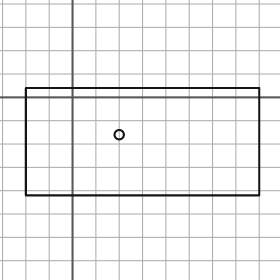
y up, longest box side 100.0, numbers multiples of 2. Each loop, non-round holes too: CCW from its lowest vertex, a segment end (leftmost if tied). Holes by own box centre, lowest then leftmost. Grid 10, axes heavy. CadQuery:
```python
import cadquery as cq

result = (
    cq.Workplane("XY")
    .moveTo(-20.0, -42.0)
    .lineTo(80.0, -42.0)
    .lineTo(80.0, 4.0)
    .lineTo(-20.0, 4.0)
    .close()
    .moveTo(20.0, -16.0)
    .circle(2.0)
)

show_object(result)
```